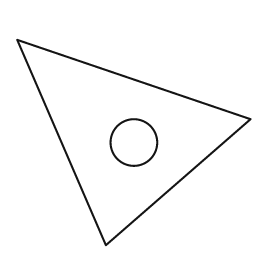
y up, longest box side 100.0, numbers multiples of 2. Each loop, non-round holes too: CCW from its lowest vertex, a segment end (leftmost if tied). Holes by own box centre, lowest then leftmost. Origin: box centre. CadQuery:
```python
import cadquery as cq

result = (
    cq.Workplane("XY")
    .moveTo(-12.0, -44.0)
    .lineTo(50.0, 10.0)
    .lineTo(-50.0, 44.0)
    .close()
    .moveTo(0.0, 0.0)
    .circle(10.0)
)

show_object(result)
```